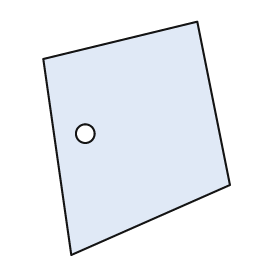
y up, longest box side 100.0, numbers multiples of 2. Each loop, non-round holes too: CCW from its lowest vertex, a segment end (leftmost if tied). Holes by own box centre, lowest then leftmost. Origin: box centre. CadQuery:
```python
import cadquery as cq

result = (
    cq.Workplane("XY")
    .moveTo(-28.0, -50.0)
    .lineTo(40.0, -20.0)
    .lineTo(26.0, 50.0)
    .lineTo(-40.0, 34.0)
    .close()
    .moveTo(-22.0, 2.0)
    .circle(4.0)
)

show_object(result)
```